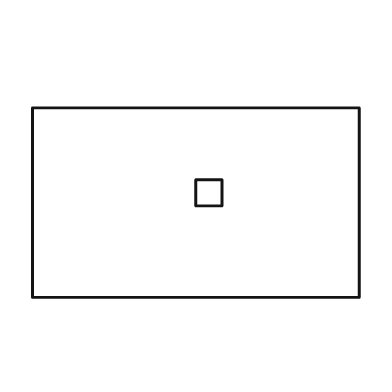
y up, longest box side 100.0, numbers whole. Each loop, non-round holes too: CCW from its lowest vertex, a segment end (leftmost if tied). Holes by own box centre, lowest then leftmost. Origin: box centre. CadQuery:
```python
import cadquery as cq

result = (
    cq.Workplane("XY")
    .moveTo(-50.0, -29.0)
    .lineTo(50.0, -29.0)
    .lineTo(50.0, 29.0)
    .lineTo(-50.0, 29.0)
    .close()
    .moveTo(0.0, -1.0)
    .lineTo(8.0, -1.0)
    .lineTo(8.0, 7.0)
    .lineTo(0.0, 7.0)
    .close()
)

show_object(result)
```